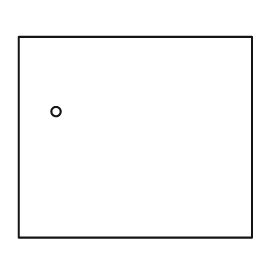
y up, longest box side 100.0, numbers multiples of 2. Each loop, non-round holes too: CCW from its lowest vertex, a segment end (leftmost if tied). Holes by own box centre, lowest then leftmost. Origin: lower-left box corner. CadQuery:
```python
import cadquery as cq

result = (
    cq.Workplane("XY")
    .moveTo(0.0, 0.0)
    .lineTo(100.0, 0.0)
    .lineTo(100.0, 86.0)
    .lineTo(0.0, 86.0)
    .close()
    .moveTo(16.0, 54.0)
    .circle(2.0)
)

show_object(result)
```